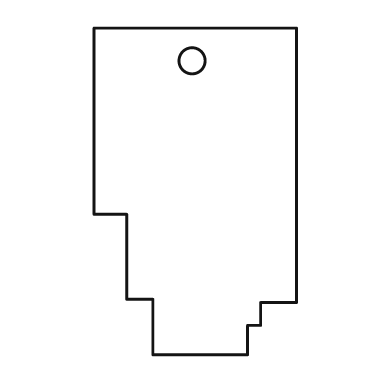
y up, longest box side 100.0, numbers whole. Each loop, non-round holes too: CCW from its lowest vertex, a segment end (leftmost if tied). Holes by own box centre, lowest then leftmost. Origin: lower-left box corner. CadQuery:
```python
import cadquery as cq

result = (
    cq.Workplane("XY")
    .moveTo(18.0, 0.0)
    .lineTo(47.0, 0.0)
    .lineTo(47.0, 9.0)
    .lineTo(51.0, 9.0)
    .lineTo(51.0, 16.0)
    .lineTo(62.0, 16.0)
    .lineTo(62.0, 100.0)
    .lineTo(0.0, 100.0)
    .lineTo(0.0, 43.0)
    .lineTo(10.0, 43.0)
    .lineTo(10.0, 17.0)
    .lineTo(18.0, 17.0)
    .close()
    .moveTo(30.0, 90.0)
    .circle(4.0)
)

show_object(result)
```